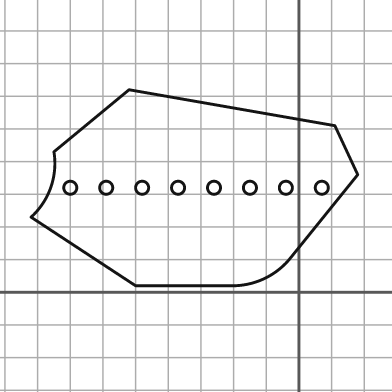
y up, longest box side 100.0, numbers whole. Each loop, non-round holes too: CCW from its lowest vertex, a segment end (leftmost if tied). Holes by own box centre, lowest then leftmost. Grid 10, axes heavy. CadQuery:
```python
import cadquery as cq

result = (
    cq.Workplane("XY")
    .moveTo(-50.0, 2.0)
    .lineTo(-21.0, 2.0)
    .threePointArc((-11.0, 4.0), (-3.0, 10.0))
    .lineTo(18.0, 36.0)
    .lineTo(11.0, 51.0)
    .lineTo(-52.0, 62.0)
    .lineTo(-75.0, 43.0)
    .threePointArc((-76.0, 32.0), (-82.0, 23.0))
    .close()
    .moveTo(-70.0, 32.0)
    .circle(2.0)
    .moveTo(-59.0, 32.0)
    .circle(2.0)
    .moveTo(-48.0, 32.0)
    .circle(2.0)
    .moveTo(-37.0, 32.0)
    .circle(2.0)
    .moveTo(-26.0, 32.0)
    .circle(2.0)
    .moveTo(-15.0, 32.0)
    .circle(2.0)
    .moveTo(-4.0, 32.0)
    .circle(2.0)
    .moveTo(7.0, 32.0)
    .circle(2.0)
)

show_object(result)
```